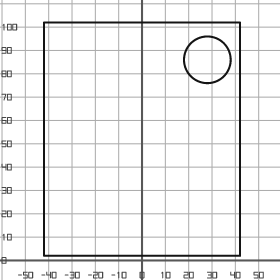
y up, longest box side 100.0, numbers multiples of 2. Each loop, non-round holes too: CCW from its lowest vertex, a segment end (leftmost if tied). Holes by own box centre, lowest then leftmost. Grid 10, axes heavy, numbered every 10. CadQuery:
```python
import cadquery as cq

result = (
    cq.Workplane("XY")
    .moveTo(-42.0, 2.0)
    .lineTo(42.0, 2.0)
    .lineTo(42.0, 102.0)
    .lineTo(-42.0, 102.0)
    .close()
    .moveTo(28.0, 86.0)
    .circle(10.0)
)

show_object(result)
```